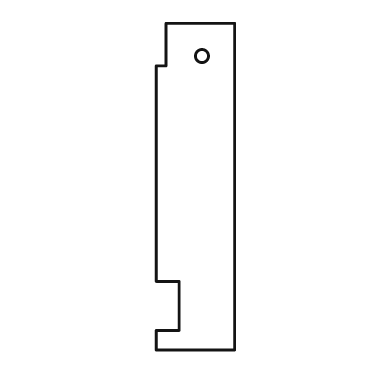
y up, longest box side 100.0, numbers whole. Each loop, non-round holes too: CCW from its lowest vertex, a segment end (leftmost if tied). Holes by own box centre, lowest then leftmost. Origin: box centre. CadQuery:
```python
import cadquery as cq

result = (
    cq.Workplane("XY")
    .moveTo(-12.0, -50.0)
    .lineTo(12.0, -50.0)
    .lineTo(12.0, 50.0)
    .lineTo(-9.0, 50.0)
    .lineTo(-9.0, 37.0)
    .lineTo(-12.0, 37.0)
    .lineTo(-12.0, -29.0)
    .lineTo(-5.0, -29.0)
    .lineTo(-5.0, -44.0)
    .lineTo(-12.0, -44.0)
    .close()
    .moveTo(2.0, 40.0)
    .circle(2.0)
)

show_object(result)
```